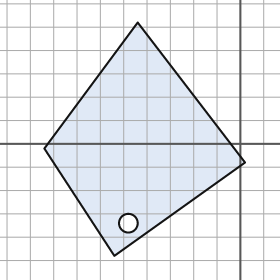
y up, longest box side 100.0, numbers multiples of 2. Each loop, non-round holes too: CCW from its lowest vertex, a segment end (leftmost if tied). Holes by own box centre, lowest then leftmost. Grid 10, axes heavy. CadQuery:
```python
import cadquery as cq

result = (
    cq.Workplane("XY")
    .moveTo(-54.0, -48.0)
    .lineTo(2.0, -8.0)
    .lineTo(-44.0, 52.0)
    .lineTo(-84.0, -2.0)
    .close()
    .moveTo(-48.0, -34.0)
    .circle(4.0)
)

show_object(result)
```